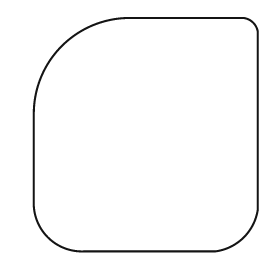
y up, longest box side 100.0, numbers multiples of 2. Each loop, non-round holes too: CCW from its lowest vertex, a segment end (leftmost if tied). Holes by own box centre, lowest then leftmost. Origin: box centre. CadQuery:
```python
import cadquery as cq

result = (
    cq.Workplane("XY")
    .moveTo(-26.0, -50.0)
    .lineTo(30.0, -50.0)
    .threePointArc((42.0, -44.0), (48.0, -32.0))
    .lineTo(48.0, 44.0)
    .threePointArc((46.0, 48.0), (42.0, 50.0))
    .lineTo(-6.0, 50.0)
    .threePointArc((-36.0, 38.0), (-48.0, 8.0))
    .lineTo(-48.0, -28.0)
    .threePointArc((-42.0, -44.0), (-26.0, -50.0))
    .close()
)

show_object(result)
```